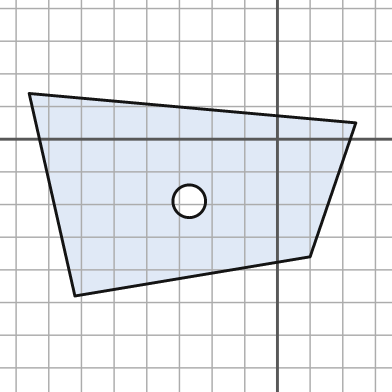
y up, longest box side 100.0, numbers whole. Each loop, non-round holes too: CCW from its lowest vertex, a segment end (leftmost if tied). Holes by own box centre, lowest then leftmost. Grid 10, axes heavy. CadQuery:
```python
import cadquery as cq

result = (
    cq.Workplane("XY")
    .moveTo(-62.0, -48.0)
    .lineTo(10.0, -36.0)
    .lineTo(24.0, 5.0)
    .lineTo(-76.0, 14.0)
    .close()
    .moveTo(-27.0, -19.0)
    .circle(5.0)
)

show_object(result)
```